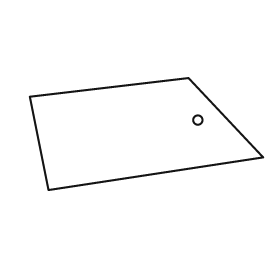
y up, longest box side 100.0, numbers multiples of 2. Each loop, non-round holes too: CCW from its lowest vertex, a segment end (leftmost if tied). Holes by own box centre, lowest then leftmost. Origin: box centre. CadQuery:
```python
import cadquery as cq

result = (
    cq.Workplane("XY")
    .moveTo(-42.0, -24.0)
    .lineTo(50.0, -10.0)
    .lineTo(18.0, 24.0)
    .lineTo(-50.0, 16.0)
    .close()
    .moveTo(22.0, 6.0)
    .circle(2.0)
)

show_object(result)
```